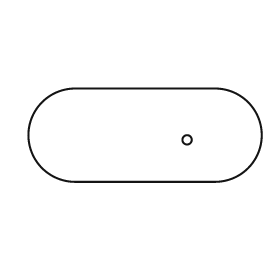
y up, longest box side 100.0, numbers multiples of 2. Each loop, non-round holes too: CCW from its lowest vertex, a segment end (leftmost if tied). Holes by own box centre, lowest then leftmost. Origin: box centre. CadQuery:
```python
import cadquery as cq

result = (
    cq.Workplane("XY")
    .moveTo(-30.0, -20.0)
    .lineTo(30.0, -20.0)
    .threePointArc((50.0, 0.0), (30.0, 20.0))
    .lineTo(-30.0, 20.0)
    .threePointArc((-50.0, 0.0), (-30.0, -20.0))
    .close()
    .moveTo(18.0, -2.0)
    .circle(2.0)
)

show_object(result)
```